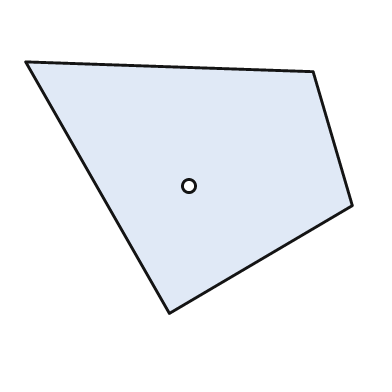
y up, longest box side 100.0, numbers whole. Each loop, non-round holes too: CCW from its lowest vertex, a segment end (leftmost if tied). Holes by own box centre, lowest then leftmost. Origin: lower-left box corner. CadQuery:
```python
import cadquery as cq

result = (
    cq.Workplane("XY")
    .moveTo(44.0, 0.0)
    .lineTo(100.0, 33.0)
    .lineTo(88.0, 74.0)
    .lineTo(0.0, 77.0)
    .close()
    .moveTo(50.0, 39.0)
    .circle(2.0)
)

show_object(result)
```